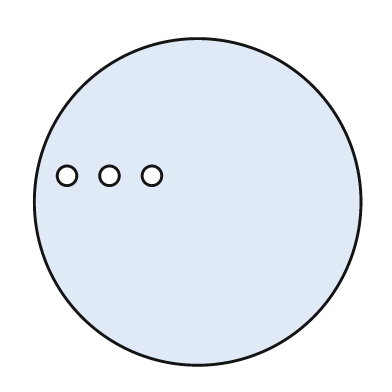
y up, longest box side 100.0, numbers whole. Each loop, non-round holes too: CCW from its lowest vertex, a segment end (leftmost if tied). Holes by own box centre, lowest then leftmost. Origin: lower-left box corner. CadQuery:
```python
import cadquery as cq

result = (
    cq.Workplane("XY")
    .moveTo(50.0, 50.0)
    .circle(50.0)
    .moveTo(10.0, 58.0)
    .circle(3.0)
    .moveTo(23.0, 58.0)
    .circle(3.0)
    .moveTo(36.0, 58.0)
    .circle(3.0)
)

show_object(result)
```